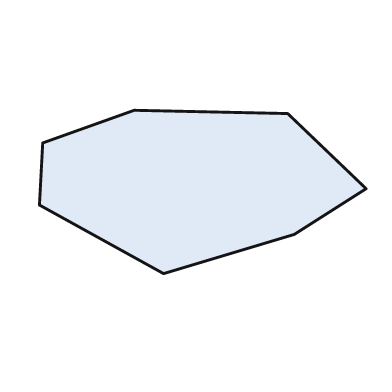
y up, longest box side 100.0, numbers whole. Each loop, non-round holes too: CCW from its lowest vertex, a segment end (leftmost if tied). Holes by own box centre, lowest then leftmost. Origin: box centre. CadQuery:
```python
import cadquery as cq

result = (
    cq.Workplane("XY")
    .moveTo(-12.0, -25.0)
    .lineTo(28.0, -13.0)
    .lineTo(50.0, 1.0)
    .lineTo(26.0, 24.0)
    .lineTo(-21.0, 25.0)
    .lineTo(-49.0, 15.0)
    .lineTo(-50.0, -4.0)
    .close()
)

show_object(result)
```